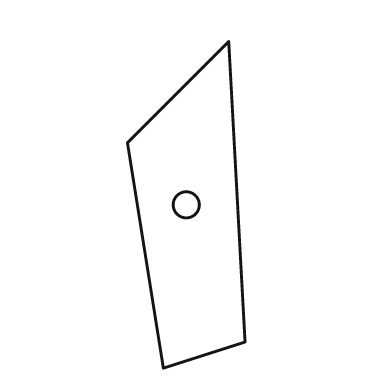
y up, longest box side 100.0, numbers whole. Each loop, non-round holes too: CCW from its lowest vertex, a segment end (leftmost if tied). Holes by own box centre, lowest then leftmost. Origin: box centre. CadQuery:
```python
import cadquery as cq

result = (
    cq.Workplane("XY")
    .moveTo(-7.0, -50.0)
    .lineTo(18.0, -42.0)
    .lineTo(13.0, 50.0)
    .lineTo(-18.0, 19.0)
    .close()
    .moveTo(0.0, 0.0)
    .circle(4.0)
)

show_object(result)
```